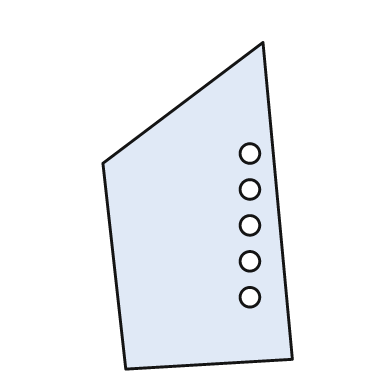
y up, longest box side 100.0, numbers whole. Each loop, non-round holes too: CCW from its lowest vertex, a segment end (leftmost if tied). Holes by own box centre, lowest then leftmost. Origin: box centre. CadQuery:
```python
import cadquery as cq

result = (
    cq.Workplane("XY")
    .moveTo(-22.0, -50.0)
    .lineTo(29.0, -47.0)
    .lineTo(20.0, 50.0)
    .lineTo(-29.0, 13.0)
    .close()
    .moveTo(16.0, -28.0)
    .circle(3.0)
    .moveTo(16.0, -17.0)
    .circle(3.0)
    .moveTo(16.0, -6.0)
    .circle(3.0)
    .moveTo(16.0, 5.0)
    .circle(3.0)
    .moveTo(16.0, 16.0)
    .circle(3.0)
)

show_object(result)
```